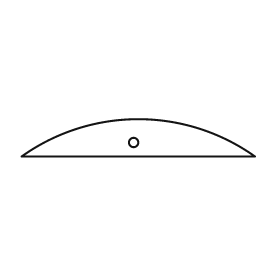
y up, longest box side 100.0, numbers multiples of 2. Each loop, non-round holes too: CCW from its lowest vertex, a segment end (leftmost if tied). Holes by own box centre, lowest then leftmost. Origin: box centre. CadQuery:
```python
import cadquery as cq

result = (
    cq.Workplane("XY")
    .moveTo(-50.0, -8.0)
    .lineTo(50.0, -8.0)
    .threePointArc((0.0, 8.0), (-50.0, -8.0))
    .close()
    .moveTo(-2.0, -2.0)
    .circle(2.0)
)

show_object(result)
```